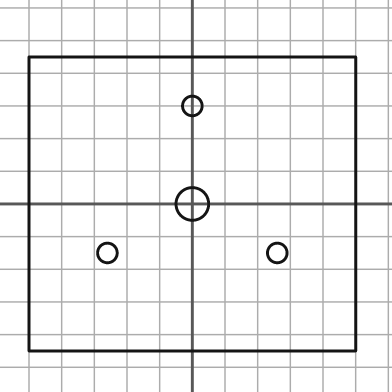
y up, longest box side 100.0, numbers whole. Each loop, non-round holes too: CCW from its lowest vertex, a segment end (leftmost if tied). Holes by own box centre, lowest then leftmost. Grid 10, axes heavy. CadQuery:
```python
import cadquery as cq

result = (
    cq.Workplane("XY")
    .moveTo(-50.0, -45.0)
    .lineTo(50.0, -45.0)
    .lineTo(50.0, 45.0)
    .lineTo(-50.0, 45.0)
    .close()
    .moveTo(-26.0, -15.0)
    .circle(3.0)
    .moveTo(26.0, -15.0)
    .circle(3.0)
    .moveTo(0.0, 0.0)
    .circle(5.0)
    .moveTo(0.0, 30.0)
    .circle(3.0)
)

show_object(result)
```